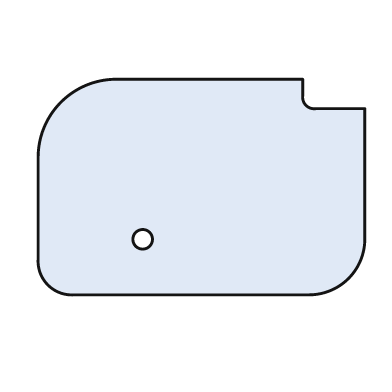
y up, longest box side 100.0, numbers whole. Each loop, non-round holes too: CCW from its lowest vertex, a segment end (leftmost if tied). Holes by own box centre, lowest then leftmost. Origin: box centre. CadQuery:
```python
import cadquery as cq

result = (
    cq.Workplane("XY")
    .moveTo(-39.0, -33.0)
    .lineTo(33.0, -33.0)
    .threePointArc((45.0, -28.0), (50.0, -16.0))
    .lineTo(50.0, 24.0)
    .lineTo(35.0, 24.0)
    .threePointArc((32.0, 25.0), (31.0, 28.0))
    .lineTo(31.0, 33.0)
    .lineTo(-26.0, 33.0)
    .threePointArc((-43.0, 26.0), (-50.0, 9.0))
    .lineTo(-50.0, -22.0)
    .threePointArc((-47.0, -30.0), (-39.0, -33.0))
    .close()
    .moveTo(-18.0, -16.0)
    .circle(3.0)
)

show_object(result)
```